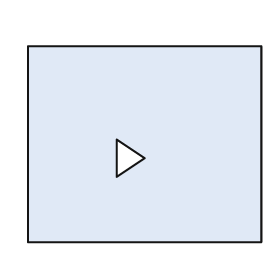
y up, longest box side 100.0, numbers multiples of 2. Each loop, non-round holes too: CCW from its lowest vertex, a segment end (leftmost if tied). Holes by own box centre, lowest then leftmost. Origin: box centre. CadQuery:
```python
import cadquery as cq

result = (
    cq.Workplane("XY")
    .moveTo(-50.0, -42.0)
    .lineTo(50.0, -42.0)
    .lineTo(50.0, 42.0)
    .lineTo(-50.0, 42.0)
    .close()
    .moveTo(-12.0, -14.0)
    .lineTo(0.0, -6.0)
    .lineTo(-12.0, 2.0)
    .close()
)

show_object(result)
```